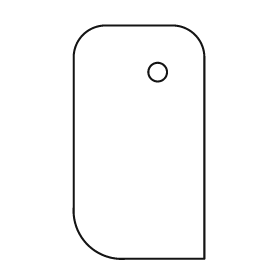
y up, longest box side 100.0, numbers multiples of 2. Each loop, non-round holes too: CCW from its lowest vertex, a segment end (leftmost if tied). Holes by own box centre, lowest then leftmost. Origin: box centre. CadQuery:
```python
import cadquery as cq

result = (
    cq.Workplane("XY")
    .moveTo(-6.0, -50.0)
    .lineTo(28.0, -50.0)
    .lineTo(28.0, 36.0)
    .threePointArc((24.0, 46.0), (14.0, 50.0))
    .lineTo(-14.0, 50.0)
    .threePointArc((-24.0, 46.0), (-28.0, 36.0))
    .lineTo(-28.0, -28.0)
    .threePointArc((-22.0, -44.0), (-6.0, -50.0))
    .close()
    .moveTo(8.0, 30.0)
    .circle(4.0)
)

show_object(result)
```